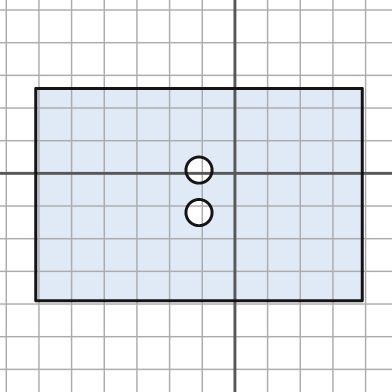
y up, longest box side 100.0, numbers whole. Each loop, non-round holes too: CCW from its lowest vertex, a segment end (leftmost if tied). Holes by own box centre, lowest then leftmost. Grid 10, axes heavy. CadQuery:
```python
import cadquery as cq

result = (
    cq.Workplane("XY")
    .moveTo(-61.0, -39.0)
    .lineTo(39.0, -39.0)
    .lineTo(39.0, 26.0)
    .lineTo(-61.0, 26.0)
    .close()
    .moveTo(-11.0, -12.0)
    .circle(4.0)
    .moveTo(-11.0, 1.0)
    .circle(4.0)
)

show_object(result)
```